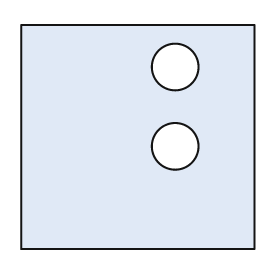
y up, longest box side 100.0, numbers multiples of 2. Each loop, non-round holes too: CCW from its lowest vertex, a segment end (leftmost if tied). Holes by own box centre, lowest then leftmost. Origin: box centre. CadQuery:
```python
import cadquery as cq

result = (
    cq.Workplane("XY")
    .moveTo(-50.0, -48.0)
    .lineTo(50.0, -48.0)
    .lineTo(50.0, 48.0)
    .lineTo(-50.0, 48.0)
    .close()
    .moveTo(16.0, -4.0)
    .circle(10.0)
    .moveTo(16.0, 30.0)
    .circle(10.0)
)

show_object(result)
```